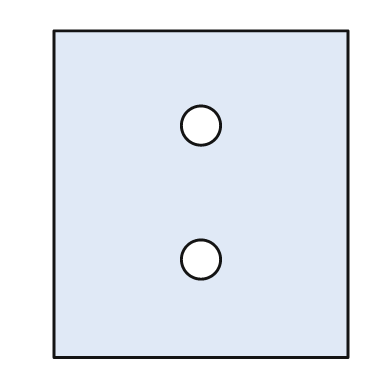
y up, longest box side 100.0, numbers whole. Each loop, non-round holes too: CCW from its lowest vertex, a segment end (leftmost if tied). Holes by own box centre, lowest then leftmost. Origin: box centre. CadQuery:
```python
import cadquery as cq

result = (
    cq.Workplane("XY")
    .moveTo(-45.0, -50.0)
    .lineTo(45.0, -50.0)
    .lineTo(45.0, 50.0)
    .lineTo(-45.0, 50.0)
    .close()
    .moveTo(0.0, -20.0)
    .circle(6.0)
    .moveTo(0.0, 21.0)
    .circle(6.0)
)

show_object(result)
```